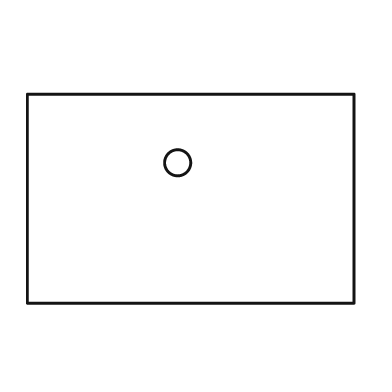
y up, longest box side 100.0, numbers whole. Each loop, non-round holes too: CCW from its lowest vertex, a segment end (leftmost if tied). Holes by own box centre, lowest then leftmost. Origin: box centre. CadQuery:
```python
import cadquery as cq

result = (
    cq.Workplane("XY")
    .moveTo(-50.0, -32.0)
    .lineTo(50.0, -32.0)
    .lineTo(50.0, 32.0)
    .lineTo(-50.0, 32.0)
    .close()
    .moveTo(-4.0, 11.0)
    .circle(4.0)
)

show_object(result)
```